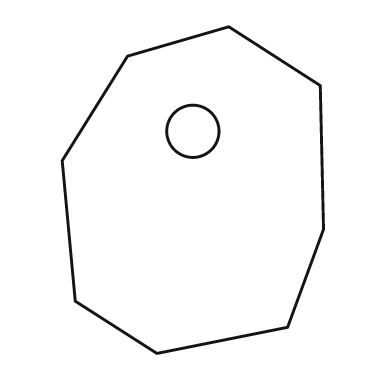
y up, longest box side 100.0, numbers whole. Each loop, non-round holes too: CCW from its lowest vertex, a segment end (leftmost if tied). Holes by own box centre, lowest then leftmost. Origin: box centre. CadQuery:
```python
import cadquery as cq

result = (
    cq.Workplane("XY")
    .moveTo(-11.0, -50.0)
    .lineTo(29.0, -42.0)
    .lineTo(40.0, -12.0)
    .lineTo(39.0, 32.0)
    .lineTo(11.0, 50.0)
    .lineTo(-20.0, 41.0)
    .lineTo(-40.0, 9.0)
    .lineTo(-36.0, -34.0)
    .close()
    .moveTo(0.0, 18.0)
    .circle(8.0)
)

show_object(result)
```